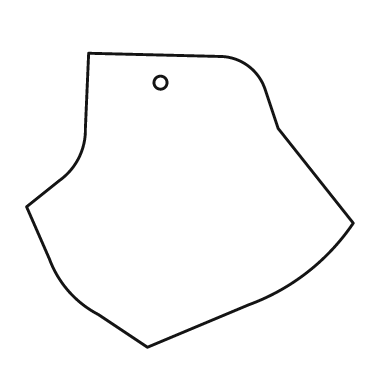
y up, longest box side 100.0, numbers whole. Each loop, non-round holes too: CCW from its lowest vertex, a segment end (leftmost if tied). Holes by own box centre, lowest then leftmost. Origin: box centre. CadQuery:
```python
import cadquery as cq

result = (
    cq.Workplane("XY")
    .moveTo(-13.0, -45.0)
    .lineTo(18.0, -32.0)
    .threePointArc((36.0, -22.0), (50.0, -7.0))
    .lineTo(27.0, 22.0)
    .lineTo(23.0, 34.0)
    .threePointArc((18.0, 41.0), (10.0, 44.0))
    .lineTo(-31.0, 45.0)
    .lineTo(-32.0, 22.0)
    .threePointArc((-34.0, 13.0), (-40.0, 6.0))
    .lineTo(-50.0, -2.0)
    .lineTo(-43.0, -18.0)
    .threePointArc((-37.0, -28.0), (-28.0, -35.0))
    .close()
    .moveTo(-9.0, 36.0)
    .circle(2.0)
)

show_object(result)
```